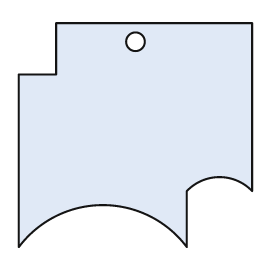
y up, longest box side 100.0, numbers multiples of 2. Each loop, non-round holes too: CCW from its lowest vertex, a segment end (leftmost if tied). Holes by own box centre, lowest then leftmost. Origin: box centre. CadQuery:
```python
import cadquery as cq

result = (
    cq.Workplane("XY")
    .moveTo(-50.0, -48.0)
    .threePointArc((-14.0, -30.0), (22.0, -48.0))
    .lineTo(22.0, -24.0)
    .threePointArc((36.0, -18.0), (50.0, -24.0))
    .lineTo(50.0, 48.0)
    .lineTo(-34.0, 48.0)
    .lineTo(-34.0, 26.0)
    .lineTo(-50.0, 26.0)
    .close()
    .moveTo(0.0, 40.0)
    .circle(4.0)
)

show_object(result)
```